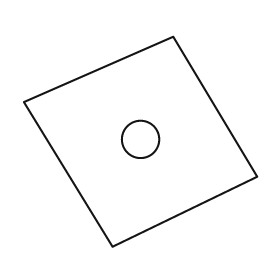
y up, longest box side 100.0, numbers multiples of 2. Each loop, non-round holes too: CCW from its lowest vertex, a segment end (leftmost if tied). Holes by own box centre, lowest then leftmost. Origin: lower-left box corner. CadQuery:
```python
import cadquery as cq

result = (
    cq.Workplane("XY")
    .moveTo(38.0, 0.0)
    .lineTo(100.0, 30.0)
    .lineTo(64.0, 90.0)
    .lineTo(0.0, 62.0)
    .close()
    .moveTo(50.0, 46.0)
    .circle(8.0)
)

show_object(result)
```